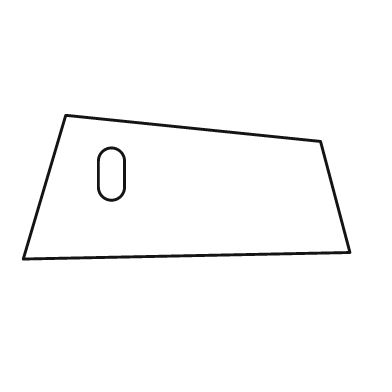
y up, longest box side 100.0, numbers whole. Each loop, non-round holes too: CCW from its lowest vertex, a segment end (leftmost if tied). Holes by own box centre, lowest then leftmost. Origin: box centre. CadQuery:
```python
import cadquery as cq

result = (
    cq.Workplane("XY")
    .moveTo(-50.0, -22.0)
    .lineTo(50.0, -20.0)
    .lineTo(41.0, 14.0)
    .lineTo(-37.0, 22.0)
    .close()
    .moveTo(-27.0, 0.0)
    .threePointArc((-23.0, -4.0), (-19.0, 0.0))
    .lineTo(-19.0, 8.0)
    .threePointArc((-23.0, 12.0), (-27.0, 8.0))
    .close()
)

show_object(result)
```